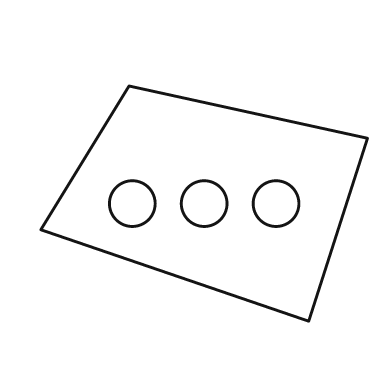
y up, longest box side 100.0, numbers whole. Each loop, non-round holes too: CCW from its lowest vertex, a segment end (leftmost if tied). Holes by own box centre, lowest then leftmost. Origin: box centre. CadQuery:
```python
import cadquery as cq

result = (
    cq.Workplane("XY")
    .moveTo(32.0, -36.0)
    .lineTo(50.0, 20.0)
    .lineTo(-23.0, 36.0)
    .lineTo(-50.0, -8.0)
    .close()
    .moveTo(-22.0, 0.0)
    .circle(7.0)
    .moveTo(0.0, 0.0)
    .circle(7.0)
    .moveTo(22.0, 0.0)
    .circle(7.0)
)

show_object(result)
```